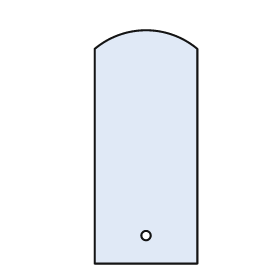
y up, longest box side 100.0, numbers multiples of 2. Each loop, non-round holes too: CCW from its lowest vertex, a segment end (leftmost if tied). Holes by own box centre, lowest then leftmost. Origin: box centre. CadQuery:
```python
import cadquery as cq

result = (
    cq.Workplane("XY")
    .moveTo(-22.0, -50.0)
    .lineTo(22.0, -50.0)
    .lineTo(22.0, 42.0)
    .threePointArc((0.0, 50.0), (-22.0, 42.0))
    .close()
    .moveTo(0.0, -38.0)
    .circle(2.0)
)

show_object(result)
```